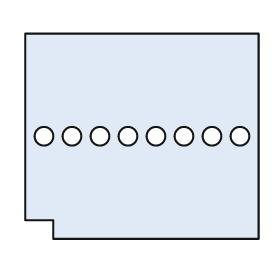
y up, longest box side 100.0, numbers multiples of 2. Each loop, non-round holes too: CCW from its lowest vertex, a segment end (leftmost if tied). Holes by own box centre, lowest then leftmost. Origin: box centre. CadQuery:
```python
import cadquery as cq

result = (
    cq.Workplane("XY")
    .moveTo(-38.0, -44.0)
    .lineTo(50.0, -44.0)
    .lineTo(50.0, 44.0)
    .lineTo(-50.0, 44.0)
    .lineTo(-50.0, -36.0)
    .lineTo(-38.0, -36.0)
    .close()
    .moveTo(-42.0, 0.0)
    .circle(4.0)
    .moveTo(-30.0, 0.0)
    .circle(4.0)
    .moveTo(-18.0, 0.0)
    .circle(4.0)
    .moveTo(-6.0, 0.0)
    .circle(4.0)
    .moveTo(6.0, 0.0)
    .circle(4.0)
    .moveTo(18.0, 0.0)
    .circle(4.0)
    .moveTo(30.0, 0.0)
    .circle(4.0)
    .moveTo(42.0, 0.0)
    .circle(4.0)
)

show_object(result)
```